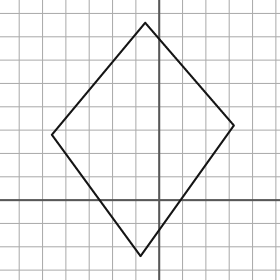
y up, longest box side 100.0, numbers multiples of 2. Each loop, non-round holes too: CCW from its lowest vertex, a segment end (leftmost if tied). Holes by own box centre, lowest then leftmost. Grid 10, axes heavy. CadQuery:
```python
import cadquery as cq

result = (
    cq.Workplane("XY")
    .moveTo(-8.0, -24.0)
    .lineTo(32.0, 32.0)
    .lineTo(-6.0, 76.0)
    .lineTo(-46.0, 28.0)
    .close()
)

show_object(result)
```